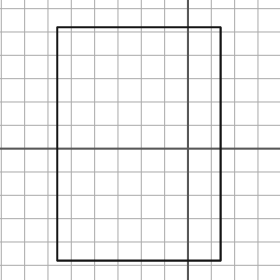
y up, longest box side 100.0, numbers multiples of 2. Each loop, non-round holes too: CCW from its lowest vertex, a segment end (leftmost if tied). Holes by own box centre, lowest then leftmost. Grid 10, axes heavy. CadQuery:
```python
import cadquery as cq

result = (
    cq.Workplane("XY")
    .moveTo(-56.0, -48.0)
    .lineTo(14.0, -48.0)
    .lineTo(14.0, 52.0)
    .lineTo(-56.0, 52.0)
    .close()
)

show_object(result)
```